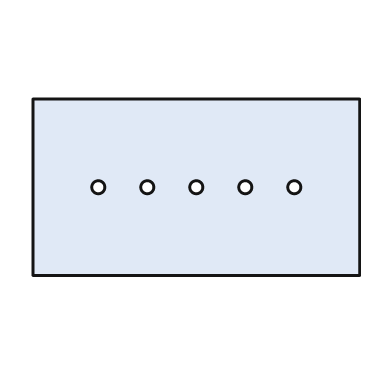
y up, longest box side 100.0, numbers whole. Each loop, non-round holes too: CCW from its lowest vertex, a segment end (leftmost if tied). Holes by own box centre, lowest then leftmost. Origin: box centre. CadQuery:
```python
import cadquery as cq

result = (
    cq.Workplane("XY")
    .moveTo(-50.0, -27.0)
    .lineTo(50.0, -27.0)
    .lineTo(50.0, 27.0)
    .lineTo(-50.0, 27.0)
    .close()
    .moveTo(-30.0, 0.0)
    .circle(2.0)
    .moveTo(-15.0, 0.0)
    .circle(2.0)
    .moveTo(0.0, 0.0)
    .circle(2.0)
    .moveTo(15.0, 0.0)
    .circle(2.0)
    .moveTo(30.0, 0.0)
    .circle(2.0)
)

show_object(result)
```